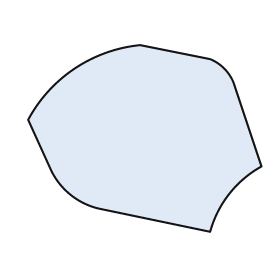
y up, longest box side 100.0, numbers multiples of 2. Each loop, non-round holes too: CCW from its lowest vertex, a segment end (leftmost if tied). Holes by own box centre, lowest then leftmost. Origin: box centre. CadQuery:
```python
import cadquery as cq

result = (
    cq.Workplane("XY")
    .moveTo(28.0, -40.0)
    .threePointArc((36.0, -24.0), (50.0, -12.0))
    .lineTo(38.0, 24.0)
    .threePointArc((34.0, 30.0), (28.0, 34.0))
    .lineTo(-2.0, 40.0)
    .threePointArc((-30.0, 30.0), (-50.0, 8.0))
    .lineTo(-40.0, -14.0)
    .threePointArc((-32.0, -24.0), (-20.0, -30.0))
    .close()
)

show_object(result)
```